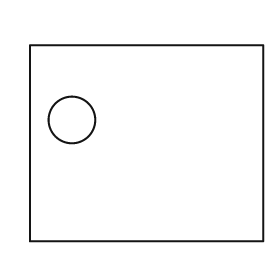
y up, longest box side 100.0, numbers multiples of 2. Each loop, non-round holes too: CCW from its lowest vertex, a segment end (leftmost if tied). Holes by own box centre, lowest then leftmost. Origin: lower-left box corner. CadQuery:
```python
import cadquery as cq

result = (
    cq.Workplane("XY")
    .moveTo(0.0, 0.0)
    .lineTo(100.0, 0.0)
    .lineTo(100.0, 84.0)
    .lineTo(0.0, 84.0)
    .close()
    .moveTo(18.0, 52.0)
    .circle(10.0)
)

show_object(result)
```